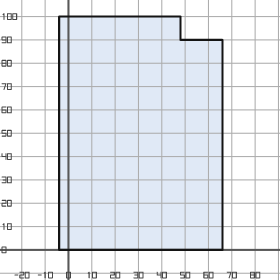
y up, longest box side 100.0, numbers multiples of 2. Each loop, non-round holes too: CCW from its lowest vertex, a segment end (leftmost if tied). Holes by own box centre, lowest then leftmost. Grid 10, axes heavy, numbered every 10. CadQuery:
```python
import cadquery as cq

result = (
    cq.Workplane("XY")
    .moveTo(-4.0, 0.0)
    .lineTo(66.0, 0.0)
    .lineTo(66.0, 90.0)
    .lineTo(48.0, 90.0)
    .lineTo(48.0, 100.0)
    .lineTo(-4.0, 100.0)
    .close()
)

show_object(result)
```